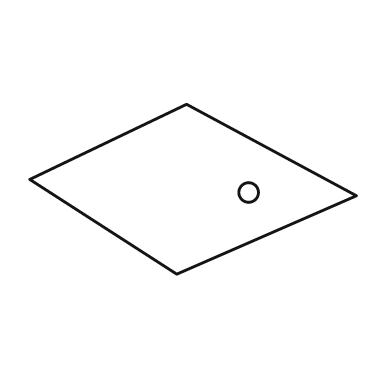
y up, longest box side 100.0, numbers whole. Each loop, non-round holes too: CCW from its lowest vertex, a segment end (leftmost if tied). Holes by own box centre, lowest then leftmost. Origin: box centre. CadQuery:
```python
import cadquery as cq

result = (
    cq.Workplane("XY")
    .moveTo(-5.0, -26.0)
    .lineTo(50.0, -2.0)
    .lineTo(-2.0, 26.0)
    .lineTo(-50.0, 3.0)
    .close()
    .moveTo(17.0, -1.0)
    .circle(3.0)
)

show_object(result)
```